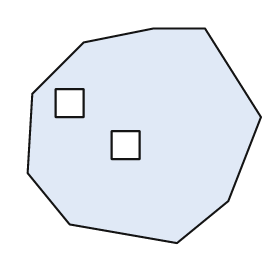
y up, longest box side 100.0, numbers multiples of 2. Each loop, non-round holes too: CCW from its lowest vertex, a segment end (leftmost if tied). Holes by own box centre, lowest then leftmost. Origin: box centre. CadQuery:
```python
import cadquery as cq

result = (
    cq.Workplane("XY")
    .moveTo(14.0, -46.0)
    .lineTo(36.0, -28.0)
    .lineTo(50.0, 8.0)
    .lineTo(26.0, 46.0)
    .lineTo(4.0, 46.0)
    .lineTo(-26.0, 40.0)
    .lineTo(-48.0, 18.0)
    .lineTo(-50.0, -16.0)
    .lineTo(-32.0, -38.0)
    .close()
    .moveTo(-14.0, -10.0)
    .lineTo(-2.0, -10.0)
    .lineTo(-2.0, 2.0)
    .lineTo(-14.0, 2.0)
    .close()
    .moveTo(-38.0, 8.0)
    .lineTo(-26.0, 8.0)
    .lineTo(-26.0, 20.0)
    .lineTo(-38.0, 20.0)
    .close()
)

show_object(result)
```